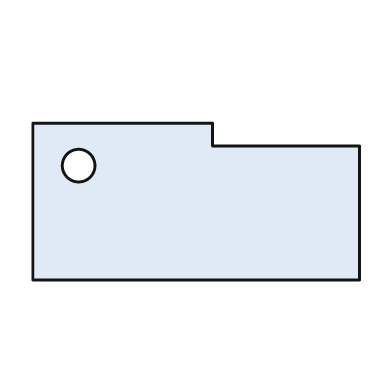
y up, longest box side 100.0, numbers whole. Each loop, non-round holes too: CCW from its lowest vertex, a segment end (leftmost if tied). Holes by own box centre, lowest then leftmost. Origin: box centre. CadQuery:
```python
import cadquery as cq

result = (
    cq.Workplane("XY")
    .moveTo(-50.0, -24.0)
    .lineTo(50.0, -24.0)
    .lineTo(50.0, 17.0)
    .lineTo(5.0, 17.0)
    .lineTo(5.0, 24.0)
    .lineTo(-50.0, 24.0)
    .close()
    .moveTo(-36.0, 11.0)
    .circle(5.0)
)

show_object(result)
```